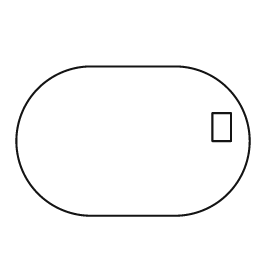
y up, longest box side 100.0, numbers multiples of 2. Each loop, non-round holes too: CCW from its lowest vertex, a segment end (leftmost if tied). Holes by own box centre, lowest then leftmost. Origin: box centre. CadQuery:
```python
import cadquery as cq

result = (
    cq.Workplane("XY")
    .moveTo(-18.0, -32.0)
    .lineTo(18.0, -32.0)
    .threePointArc((50.0, 0.0), (18.0, 32.0))
    .lineTo(-18.0, 32.0)
    .threePointArc((-50.0, 0.0), (-18.0, -32.0))
    .close()
    .moveTo(34.0, 0.0)
    .lineTo(42.0, 0.0)
    .lineTo(42.0, 12.0)
    .lineTo(34.0, 12.0)
    .close()
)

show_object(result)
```